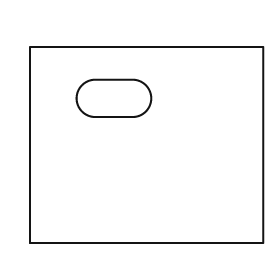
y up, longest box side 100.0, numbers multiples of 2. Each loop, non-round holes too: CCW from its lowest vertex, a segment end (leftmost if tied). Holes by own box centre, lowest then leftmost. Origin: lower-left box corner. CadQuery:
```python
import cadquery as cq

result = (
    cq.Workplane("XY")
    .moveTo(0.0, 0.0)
    .lineTo(100.0, 0.0)
    .lineTo(100.0, 84.0)
    .lineTo(0.0, 84.0)
    .close()
    .moveTo(28.0, 54.0)
    .lineTo(44.0, 54.0)
    .threePointArc((52.0, 62.0), (44.0, 70.0))
    .lineTo(28.0, 70.0)
    .threePointArc((20.0, 62.0), (28.0, 54.0))
    .close()
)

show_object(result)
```